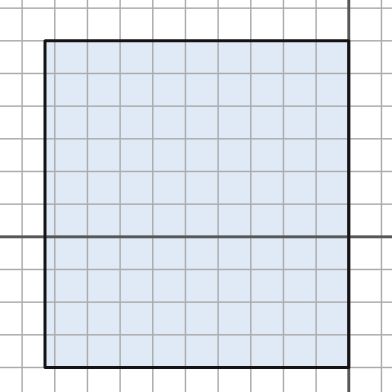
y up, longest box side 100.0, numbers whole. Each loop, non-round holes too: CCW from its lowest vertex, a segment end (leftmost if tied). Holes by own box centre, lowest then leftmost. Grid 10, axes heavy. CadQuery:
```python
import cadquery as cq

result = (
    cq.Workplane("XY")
    .moveTo(-93.0, -40.0)
    .lineTo(0.0, -40.0)
    .lineTo(0.0, 60.0)
    .lineTo(-93.0, 60.0)
    .close()
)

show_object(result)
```